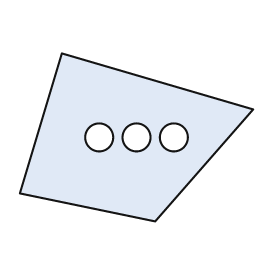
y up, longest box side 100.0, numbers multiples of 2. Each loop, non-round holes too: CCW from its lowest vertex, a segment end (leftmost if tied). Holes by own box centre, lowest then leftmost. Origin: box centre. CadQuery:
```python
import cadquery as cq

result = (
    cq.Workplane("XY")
    .moveTo(8.0, -36.0)
    .lineTo(50.0, 12.0)
    .lineTo(-32.0, 36.0)
    .lineTo(-50.0, -24.0)
    .close()
    .moveTo(-16.0, 0.0)
    .circle(6.0)
    .moveTo(0.0, 0.0)
    .circle(6.0)
    .moveTo(16.0, 0.0)
    .circle(6.0)
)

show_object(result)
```